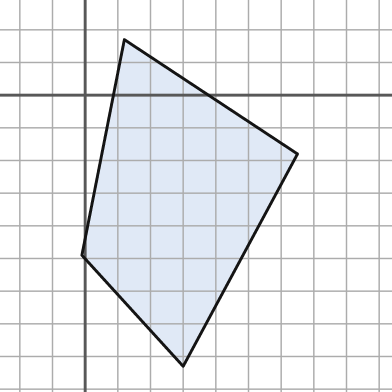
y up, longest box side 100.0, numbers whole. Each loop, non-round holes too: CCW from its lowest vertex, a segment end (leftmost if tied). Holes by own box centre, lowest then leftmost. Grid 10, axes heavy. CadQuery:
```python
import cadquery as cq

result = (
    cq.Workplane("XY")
    .moveTo(30.0, -83.0)
    .lineTo(65.0, -18.0)
    .lineTo(12.0, 17.0)
    .lineTo(-1.0, -49.0)
    .close()
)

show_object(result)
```